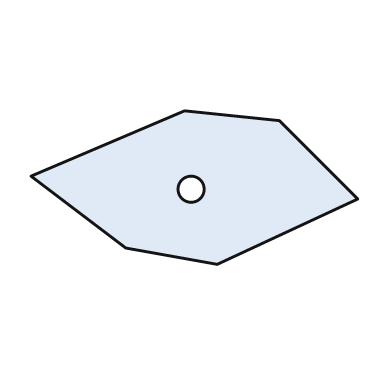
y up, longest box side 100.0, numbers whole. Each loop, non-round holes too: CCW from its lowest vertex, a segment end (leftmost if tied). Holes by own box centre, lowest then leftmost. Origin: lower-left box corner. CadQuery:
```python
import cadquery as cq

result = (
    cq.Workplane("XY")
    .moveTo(57.0, 0.0)
    .lineTo(100.0, 20.0)
    .lineTo(76.0, 44.0)
    .lineTo(47.0, 47.0)
    .lineTo(0.0, 27.0)
    .lineTo(29.0, 5.0)
    .close()
    .moveTo(49.0, 23.0)
    .circle(4.0)
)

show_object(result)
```